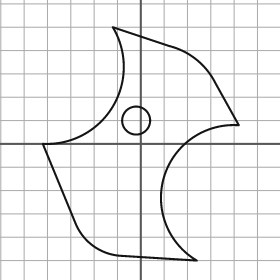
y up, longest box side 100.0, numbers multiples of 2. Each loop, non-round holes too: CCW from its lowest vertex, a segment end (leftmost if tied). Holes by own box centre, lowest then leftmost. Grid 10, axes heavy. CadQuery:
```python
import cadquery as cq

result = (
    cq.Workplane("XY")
    .moveTo(24.0, -50.0)
    .threePointArc((10.0, -14.0), (42.0, 8.0))
    .lineTo(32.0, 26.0)
    .threePointArc((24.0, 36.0), (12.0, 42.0))
    .lineTo(-12.0, 50.0)
    .threePointArc((-12.0, 16.0), (-42.0, 0.0))
    .lineTo(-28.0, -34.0)
    .threePointArc((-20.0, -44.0), (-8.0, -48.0))
    .close()
    .moveTo(-2.0, 10.0)
    .circle(6.0)
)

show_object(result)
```